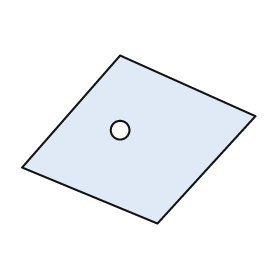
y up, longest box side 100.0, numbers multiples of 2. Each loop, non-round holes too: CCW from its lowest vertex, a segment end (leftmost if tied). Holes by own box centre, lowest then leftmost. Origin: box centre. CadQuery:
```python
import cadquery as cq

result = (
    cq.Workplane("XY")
    .moveTo(8.0, -36.0)
    .lineTo(50.0, 10.0)
    .lineTo(-8.0, 36.0)
    .lineTo(-50.0, -12.0)
    .close()
    .moveTo(-8.0, 4.0)
    .circle(4.0)
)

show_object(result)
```